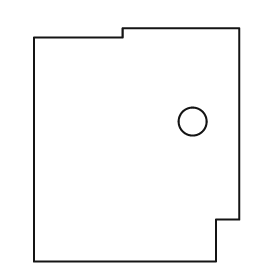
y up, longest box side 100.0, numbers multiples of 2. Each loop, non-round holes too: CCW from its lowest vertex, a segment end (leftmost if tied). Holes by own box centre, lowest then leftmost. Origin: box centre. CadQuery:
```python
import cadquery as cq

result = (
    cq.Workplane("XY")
    .moveTo(-44.0, -50.0)
    .lineTo(34.0, -50.0)
    .lineTo(34.0, -32.0)
    .lineTo(44.0, -32.0)
    .lineTo(44.0, 50.0)
    .lineTo(-6.0, 50.0)
    .lineTo(-6.0, 46.0)
    .lineTo(-44.0, 46.0)
    .close()
    .moveTo(24.0, 10.0)
    .circle(6.0)
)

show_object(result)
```